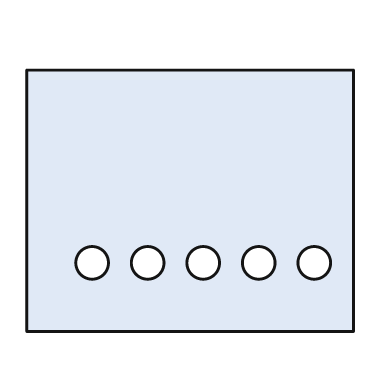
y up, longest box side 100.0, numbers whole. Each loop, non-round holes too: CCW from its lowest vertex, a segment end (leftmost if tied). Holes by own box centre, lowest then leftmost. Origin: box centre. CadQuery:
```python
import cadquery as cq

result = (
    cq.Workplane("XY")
    .moveTo(-50.0, -40.0)
    .lineTo(50.0, -40.0)
    .lineTo(50.0, 40.0)
    .lineTo(-50.0, 40.0)
    .close()
    .moveTo(-30.0, -19.0)
    .circle(5.0)
    .moveTo(-13.0, -19.0)
    .circle(5.0)
    .moveTo(4.0, -19.0)
    .circle(5.0)
    .moveTo(21.0, -19.0)
    .circle(5.0)
    .moveTo(38.0, -19.0)
    .circle(5.0)
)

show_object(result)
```